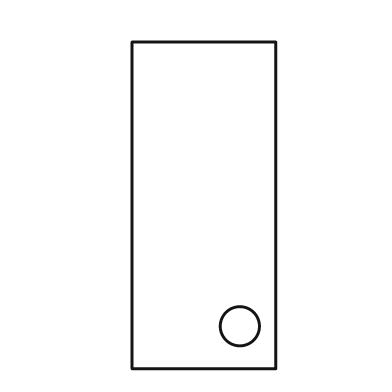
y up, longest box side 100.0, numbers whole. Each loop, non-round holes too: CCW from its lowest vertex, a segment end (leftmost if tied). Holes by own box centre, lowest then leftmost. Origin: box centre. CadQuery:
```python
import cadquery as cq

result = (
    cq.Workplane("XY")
    .moveTo(-22.0, -50.0)
    .lineTo(22.0, -50.0)
    .lineTo(22.0, 50.0)
    .lineTo(-22.0, 50.0)
    .close()
    .moveTo(11.0, -37.0)
    .circle(6.0)
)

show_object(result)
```